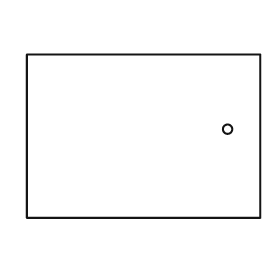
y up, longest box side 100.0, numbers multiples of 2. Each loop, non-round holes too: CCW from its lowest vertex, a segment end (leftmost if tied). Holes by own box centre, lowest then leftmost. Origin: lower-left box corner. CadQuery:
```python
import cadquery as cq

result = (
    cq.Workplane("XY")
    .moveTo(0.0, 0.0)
    .lineTo(100.0, 0.0)
    .lineTo(100.0, 70.0)
    .lineTo(0.0, 70.0)
    .close()
    .moveTo(86.0, 38.0)
    .circle(2.0)
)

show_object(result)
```